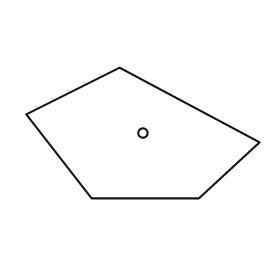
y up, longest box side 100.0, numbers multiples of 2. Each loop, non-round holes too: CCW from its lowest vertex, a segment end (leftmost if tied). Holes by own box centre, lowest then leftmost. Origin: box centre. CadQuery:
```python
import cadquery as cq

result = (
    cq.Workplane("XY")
    .moveTo(-22.0, -28.0)
    .lineTo(24.0, -28.0)
    .lineTo(50.0, -4.0)
    .lineTo(-10.0, 28.0)
    .lineTo(-50.0, 8.0)
    .close()
    .moveTo(0.0, 0.0)
    .circle(2.0)
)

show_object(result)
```